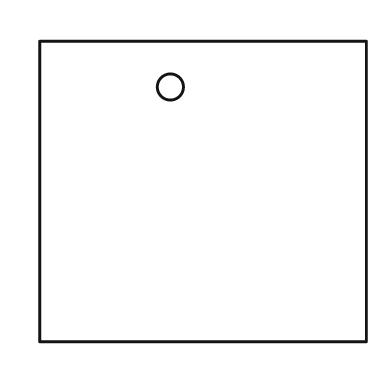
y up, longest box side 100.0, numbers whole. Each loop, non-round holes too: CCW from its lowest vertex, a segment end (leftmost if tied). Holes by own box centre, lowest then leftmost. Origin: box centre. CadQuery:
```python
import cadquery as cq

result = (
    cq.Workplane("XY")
    .moveTo(-50.0, -46.0)
    .lineTo(50.0, -46.0)
    .lineTo(50.0, 46.0)
    .lineTo(-50.0, 46.0)
    .close()
    .moveTo(-10.0, 32.0)
    .circle(4.0)
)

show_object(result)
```